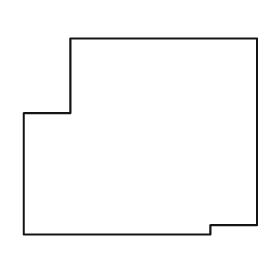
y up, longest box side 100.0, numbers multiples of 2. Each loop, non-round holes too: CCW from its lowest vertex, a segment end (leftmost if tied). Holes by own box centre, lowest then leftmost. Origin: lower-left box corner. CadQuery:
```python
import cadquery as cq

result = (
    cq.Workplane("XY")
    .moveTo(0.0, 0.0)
    .lineTo(80.0, 0.0)
    .lineTo(80.0, 4.0)
    .lineTo(100.0, 4.0)
    .lineTo(100.0, 84.0)
    .lineTo(20.0, 84.0)
    .lineTo(20.0, 52.0)
    .lineTo(0.0, 52.0)
    .close()
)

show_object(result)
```